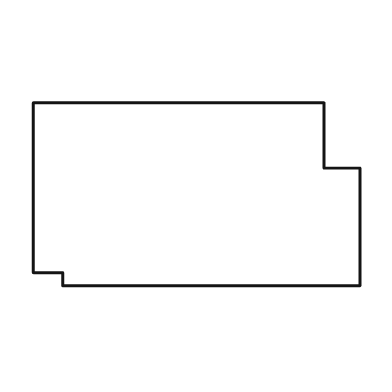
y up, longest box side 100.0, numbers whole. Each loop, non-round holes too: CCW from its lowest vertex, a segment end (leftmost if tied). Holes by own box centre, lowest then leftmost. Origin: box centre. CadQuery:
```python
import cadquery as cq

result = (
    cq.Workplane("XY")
    .moveTo(-41.0, -28.0)
    .lineTo(50.0, -28.0)
    .lineTo(50.0, 8.0)
    .lineTo(39.0, 8.0)
    .lineTo(39.0, 28.0)
    .lineTo(-50.0, 28.0)
    .lineTo(-50.0, -24.0)
    .lineTo(-41.0, -24.0)
    .close()
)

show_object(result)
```